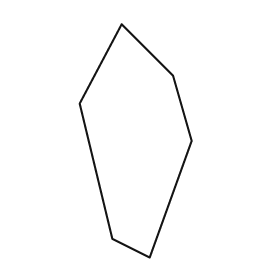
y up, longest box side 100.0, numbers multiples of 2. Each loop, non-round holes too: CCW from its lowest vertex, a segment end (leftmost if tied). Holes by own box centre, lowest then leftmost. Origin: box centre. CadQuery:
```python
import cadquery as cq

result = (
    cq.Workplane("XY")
    .moveTo(6.0, -50.0)
    .lineTo(24.0, 0.0)
    .lineTo(16.0, 28.0)
    .lineTo(-6.0, 50.0)
    .lineTo(-24.0, 16.0)
    .lineTo(-10.0, -42.0)
    .close()
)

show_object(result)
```